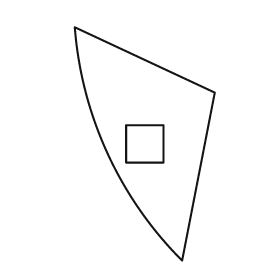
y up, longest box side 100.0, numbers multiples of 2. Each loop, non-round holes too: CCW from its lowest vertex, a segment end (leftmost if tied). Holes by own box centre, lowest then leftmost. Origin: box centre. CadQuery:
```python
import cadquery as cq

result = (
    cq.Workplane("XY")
    .moveTo(16.0, -50.0)
    .lineTo(30.0, 22.0)
    .lineTo(-30.0, 50.0)
    .threePointArc((-16.0, -4.0), (16.0, -50.0))
    .close()
    .moveTo(-8.0, -8.0)
    .lineTo(8.0, -8.0)
    .lineTo(8.0, 8.0)
    .lineTo(-8.0, 8.0)
    .close()
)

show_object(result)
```